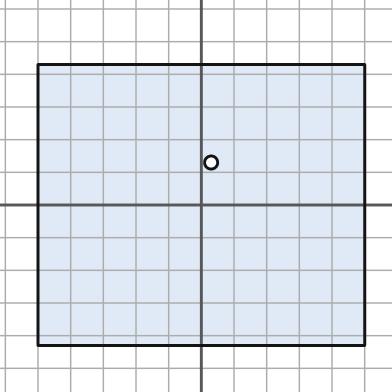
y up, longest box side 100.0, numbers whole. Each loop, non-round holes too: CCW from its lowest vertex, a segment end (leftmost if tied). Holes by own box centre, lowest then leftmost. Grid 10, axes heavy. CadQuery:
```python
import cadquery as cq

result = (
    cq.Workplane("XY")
    .moveTo(-50.0, -43.0)
    .lineTo(50.0, -43.0)
    .lineTo(50.0, 43.0)
    .lineTo(-50.0, 43.0)
    .close()
    .moveTo(3.0, 13.0)
    .circle(2.0)
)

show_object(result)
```